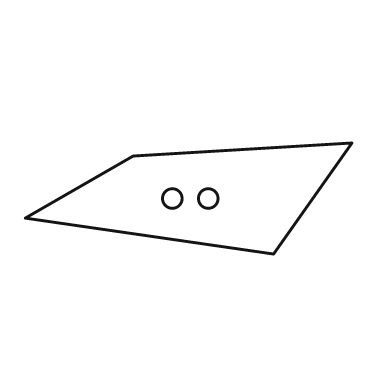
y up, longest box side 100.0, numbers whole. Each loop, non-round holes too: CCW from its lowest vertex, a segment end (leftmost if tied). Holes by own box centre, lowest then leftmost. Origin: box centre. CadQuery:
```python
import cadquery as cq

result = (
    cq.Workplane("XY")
    .moveTo(26.0, -17.0)
    .lineTo(50.0, 17.0)
    .lineTo(-17.0, 13.0)
    .lineTo(-50.0, -6.0)
    .close()
    .moveTo(-5.0, 0.0)
    .circle(3.0)
    .moveTo(6.0, 0.0)
    .circle(3.0)
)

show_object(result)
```